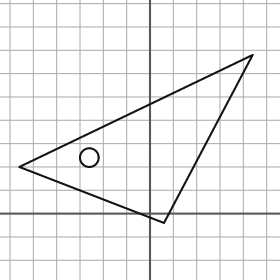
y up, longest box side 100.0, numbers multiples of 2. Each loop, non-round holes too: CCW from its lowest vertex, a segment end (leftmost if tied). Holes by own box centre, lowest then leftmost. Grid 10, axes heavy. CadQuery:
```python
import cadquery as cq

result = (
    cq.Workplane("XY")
    .moveTo(6.0, -4.0)
    .lineTo(44.0, 68.0)
    .lineTo(-56.0, 20.0)
    .close()
    .moveTo(-26.0, 24.0)
    .circle(4.0)
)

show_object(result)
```